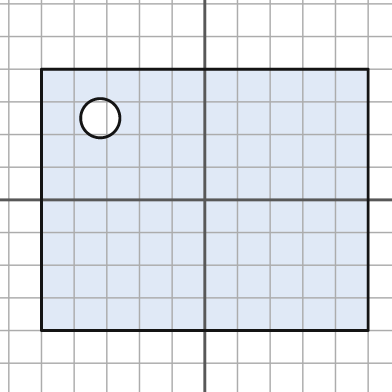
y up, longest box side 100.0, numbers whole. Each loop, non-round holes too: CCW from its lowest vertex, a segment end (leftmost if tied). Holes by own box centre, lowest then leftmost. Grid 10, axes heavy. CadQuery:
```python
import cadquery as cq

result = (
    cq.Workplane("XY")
    .moveTo(-50.0, -40.0)
    .lineTo(50.0, -40.0)
    .lineTo(50.0, 40.0)
    .lineTo(-50.0, 40.0)
    .close()
    .moveTo(-32.0, 25.0)
    .circle(6.0)
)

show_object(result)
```